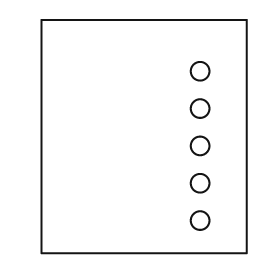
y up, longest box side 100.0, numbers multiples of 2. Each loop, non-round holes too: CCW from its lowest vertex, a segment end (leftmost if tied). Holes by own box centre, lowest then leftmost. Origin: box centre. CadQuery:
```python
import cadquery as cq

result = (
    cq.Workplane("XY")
    .moveTo(-44.0, -50.0)
    .lineTo(44.0, -50.0)
    .lineTo(44.0, 50.0)
    .lineTo(-44.0, 50.0)
    .close()
    .moveTo(24.0, -36.0)
    .circle(4.0)
    .moveTo(24.0, -20.0)
    .circle(4.0)
    .moveTo(24.0, -4.0)
    .circle(4.0)
    .moveTo(24.0, 12.0)
    .circle(4.0)
    .moveTo(24.0, 28.0)
    .circle(4.0)
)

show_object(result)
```